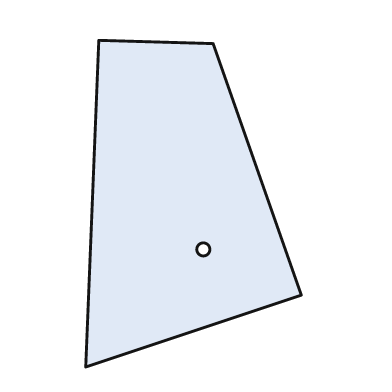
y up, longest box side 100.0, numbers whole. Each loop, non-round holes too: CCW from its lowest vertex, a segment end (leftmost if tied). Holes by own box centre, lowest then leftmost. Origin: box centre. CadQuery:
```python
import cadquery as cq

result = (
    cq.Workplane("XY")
    .moveTo(-33.0, -50.0)
    .lineTo(33.0, -28.0)
    .lineTo(6.0, 49.0)
    .lineTo(-29.0, 50.0)
    .close()
    .moveTo(3.0, -14.0)
    .circle(2.0)
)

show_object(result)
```